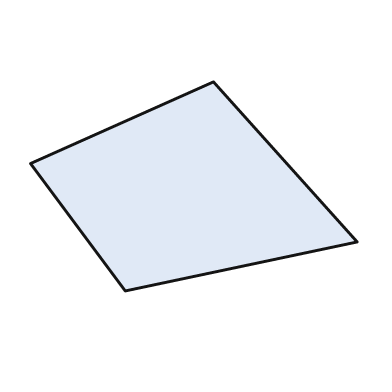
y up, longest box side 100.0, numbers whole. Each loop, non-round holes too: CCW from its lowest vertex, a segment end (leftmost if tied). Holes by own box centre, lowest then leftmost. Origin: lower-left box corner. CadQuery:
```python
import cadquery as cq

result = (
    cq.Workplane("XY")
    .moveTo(29.0, 0.0)
    .lineTo(100.0, 15.0)
    .lineTo(56.0, 64.0)
    .lineTo(0.0, 39.0)
    .close()
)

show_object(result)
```